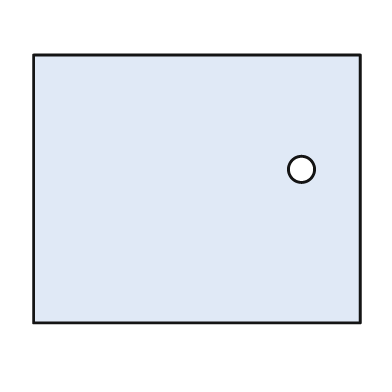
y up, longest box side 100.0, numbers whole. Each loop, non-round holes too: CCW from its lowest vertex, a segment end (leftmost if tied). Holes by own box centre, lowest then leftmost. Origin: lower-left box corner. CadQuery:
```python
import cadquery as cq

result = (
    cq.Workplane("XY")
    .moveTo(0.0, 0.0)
    .lineTo(100.0, 0.0)
    .lineTo(100.0, 82.0)
    .lineTo(0.0, 82.0)
    .close()
    .moveTo(82.0, 47.0)
    .circle(4.0)
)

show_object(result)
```